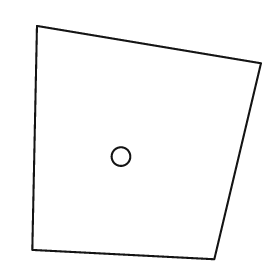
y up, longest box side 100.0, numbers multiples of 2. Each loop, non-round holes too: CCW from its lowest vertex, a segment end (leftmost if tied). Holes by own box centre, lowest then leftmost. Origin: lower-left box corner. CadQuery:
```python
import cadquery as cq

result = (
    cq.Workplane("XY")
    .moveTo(78.0, 0.0)
    .lineTo(98.0, 84.0)
    .lineTo(2.0, 100.0)
    .lineTo(0.0, 4.0)
    .close()
    .moveTo(38.0, 44.0)
    .circle(4.0)
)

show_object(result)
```